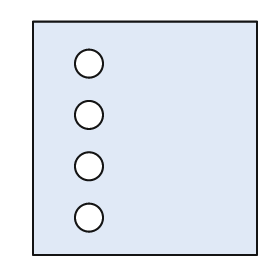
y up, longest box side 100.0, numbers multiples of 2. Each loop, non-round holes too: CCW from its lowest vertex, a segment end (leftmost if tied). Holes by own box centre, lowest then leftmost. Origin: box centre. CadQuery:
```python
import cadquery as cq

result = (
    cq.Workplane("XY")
    .moveTo(-48.0, -50.0)
    .lineTo(48.0, -50.0)
    .lineTo(48.0, 50.0)
    .lineTo(-48.0, 50.0)
    .close()
    .moveTo(-24.0, -34.0)
    .circle(6.0)
    .moveTo(-24.0, -12.0)
    .circle(6.0)
    .moveTo(-24.0, 10.0)
    .circle(6.0)
    .moveTo(-24.0, 32.0)
    .circle(6.0)
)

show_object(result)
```